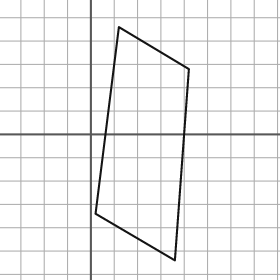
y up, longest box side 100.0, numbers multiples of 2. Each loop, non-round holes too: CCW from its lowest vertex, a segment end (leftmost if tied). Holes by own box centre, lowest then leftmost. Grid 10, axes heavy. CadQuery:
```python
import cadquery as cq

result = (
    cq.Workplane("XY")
    .moveTo(36.0, -54.0)
    .lineTo(42.0, 28.0)
    .lineTo(12.0, 46.0)
    .lineTo(2.0, -34.0)
    .close()
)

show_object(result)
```